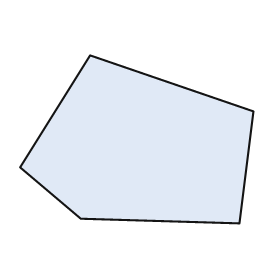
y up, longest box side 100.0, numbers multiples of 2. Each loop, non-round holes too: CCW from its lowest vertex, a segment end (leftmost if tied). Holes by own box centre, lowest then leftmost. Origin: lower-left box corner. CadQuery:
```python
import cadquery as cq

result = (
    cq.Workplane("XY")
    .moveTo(94.0, 0.0)
    .lineTo(100.0, 48.0)
    .lineTo(30.0, 72.0)
    .lineTo(0.0, 24.0)
    .lineTo(26.0, 2.0)
    .close()
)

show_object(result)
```